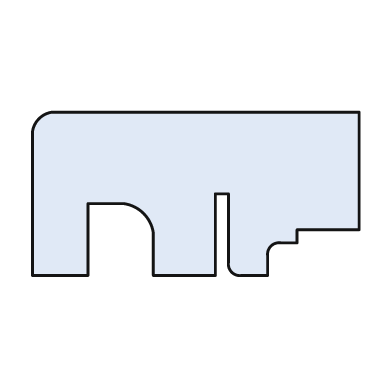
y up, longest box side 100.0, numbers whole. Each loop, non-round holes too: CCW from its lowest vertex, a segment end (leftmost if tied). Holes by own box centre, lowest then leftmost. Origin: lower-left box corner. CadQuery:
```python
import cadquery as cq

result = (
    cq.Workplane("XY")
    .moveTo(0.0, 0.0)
    .lineTo(17.0, 0.0)
    .lineTo(17.0, 22.0)
    .lineTo(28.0, 22.0)
    .threePointArc((34.0, 19.0), (37.0, 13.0))
    .lineTo(37.0, 0.0)
    .lineTo(56.0, 0.0)
    .lineTo(56.0, 25.0)
    .lineTo(60.0, 25.0)
    .lineTo(60.0, 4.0)
    .threePointArc((61.0, 1.0), (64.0, 0.0))
    .lineTo(72.0, 0.0)
    .lineTo(72.0, 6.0)
    .threePointArc((73.0, 9.0), (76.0, 10.0))
    .lineTo(81.0, 10.0)
    .lineTo(81.0, 14.0)
    .lineTo(100.0, 14.0)
    .lineTo(100.0, 50.0)
    .lineTo(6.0, 50.0)
    .threePointArc((2.0, 48.0), (0.0, 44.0))
    .close()
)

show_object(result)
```